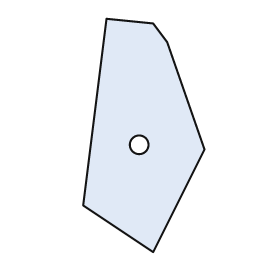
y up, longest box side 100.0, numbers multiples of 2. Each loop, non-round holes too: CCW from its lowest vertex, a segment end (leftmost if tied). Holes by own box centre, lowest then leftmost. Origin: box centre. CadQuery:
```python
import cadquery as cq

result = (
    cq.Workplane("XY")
    .moveTo(4.0, -50.0)
    .lineTo(26.0, -6.0)
    .lineTo(10.0, 40.0)
    .lineTo(4.0, 48.0)
    .lineTo(-16.0, 50.0)
    .lineTo(-26.0, -30.0)
    .close()
    .moveTo(-2.0, -4.0)
    .circle(4.0)
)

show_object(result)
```